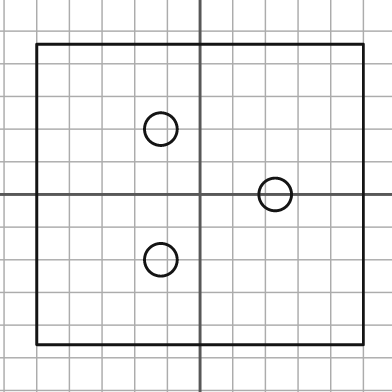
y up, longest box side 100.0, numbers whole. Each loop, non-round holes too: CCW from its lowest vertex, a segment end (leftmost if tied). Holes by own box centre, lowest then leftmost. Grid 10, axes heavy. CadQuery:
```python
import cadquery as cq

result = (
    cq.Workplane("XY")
    .moveTo(-50.0, -46.0)
    .lineTo(50.0, -46.0)
    .lineTo(50.0, 46.0)
    .lineTo(-50.0, 46.0)
    .close()
    .moveTo(-12.0, -20.0)
    .circle(5.0)
    .moveTo(23.0, 0.0)
    .circle(5.0)
    .moveTo(-12.0, 20.0)
    .circle(5.0)
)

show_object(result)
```